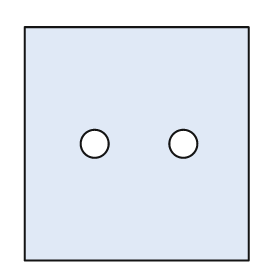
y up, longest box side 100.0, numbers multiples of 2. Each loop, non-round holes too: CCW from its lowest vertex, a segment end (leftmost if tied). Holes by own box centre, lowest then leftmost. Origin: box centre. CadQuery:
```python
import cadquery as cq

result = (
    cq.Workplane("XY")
    .moveTo(-48.0, -50.0)
    .lineTo(48.0, -50.0)
    .lineTo(48.0, 50.0)
    .lineTo(-48.0, 50.0)
    .close()
    .moveTo(-18.0, 0.0)
    .circle(6.0)
    .moveTo(20.0, 0.0)
    .circle(6.0)
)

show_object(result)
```